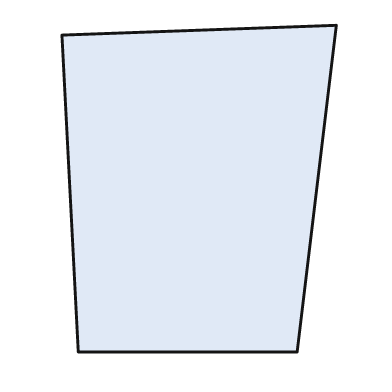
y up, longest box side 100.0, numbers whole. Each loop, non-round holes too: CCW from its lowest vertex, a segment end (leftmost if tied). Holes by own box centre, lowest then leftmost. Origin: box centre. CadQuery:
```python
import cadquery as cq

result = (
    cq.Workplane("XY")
    .moveTo(-37.0, -50.0)
    .lineTo(30.0, -50.0)
    .lineTo(42.0, 50.0)
    .lineTo(-42.0, 47.0)
    .close()
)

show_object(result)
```